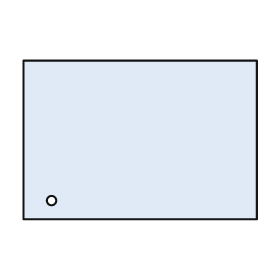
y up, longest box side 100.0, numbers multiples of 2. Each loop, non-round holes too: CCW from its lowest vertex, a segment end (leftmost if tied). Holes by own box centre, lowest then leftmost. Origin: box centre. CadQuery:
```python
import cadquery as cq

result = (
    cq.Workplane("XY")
    .moveTo(-50.0, -34.0)
    .lineTo(50.0, -34.0)
    .lineTo(50.0, 34.0)
    .lineTo(-50.0, 34.0)
    .close()
    .moveTo(-38.0, -26.0)
    .circle(2.0)
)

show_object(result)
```